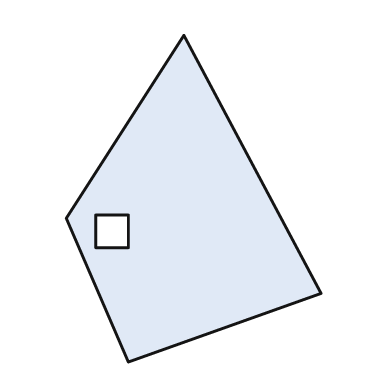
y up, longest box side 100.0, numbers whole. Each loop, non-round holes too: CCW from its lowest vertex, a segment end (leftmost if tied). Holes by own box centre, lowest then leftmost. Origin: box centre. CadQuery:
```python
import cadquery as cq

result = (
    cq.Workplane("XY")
    .moveTo(-20.0, -50.0)
    .lineTo(39.0, -29.0)
    .lineTo(-3.0, 50.0)
    .lineTo(-39.0, -6.0)
    .close()
    .moveTo(-30.0, -15.0)
    .lineTo(-20.0, -15.0)
    .lineTo(-20.0, -5.0)
    .lineTo(-30.0, -5.0)
    .close()
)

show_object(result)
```